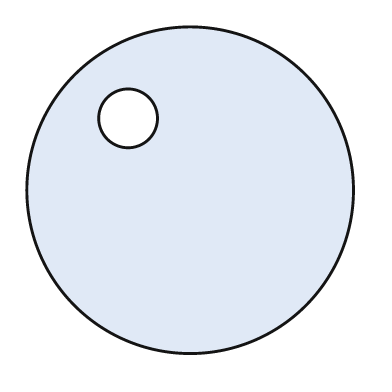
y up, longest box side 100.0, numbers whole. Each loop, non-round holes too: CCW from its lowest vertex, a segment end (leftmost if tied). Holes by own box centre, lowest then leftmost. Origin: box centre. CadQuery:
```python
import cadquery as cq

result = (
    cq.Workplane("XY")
    .moveTo(0.0, 0.0)
    .circle(50.0)
    .moveTo(-19.0, 22.0)
    .circle(9.0)
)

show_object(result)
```